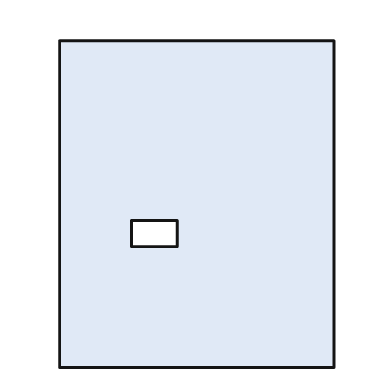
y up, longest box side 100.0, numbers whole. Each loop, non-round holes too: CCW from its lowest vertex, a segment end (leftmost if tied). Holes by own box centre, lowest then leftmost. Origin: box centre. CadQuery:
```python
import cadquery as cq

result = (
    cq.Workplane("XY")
    .moveTo(-42.0, -50.0)
    .lineTo(42.0, -50.0)
    .lineTo(42.0, 50.0)
    .lineTo(-42.0, 50.0)
    .close()
    .moveTo(-20.0, -13.0)
    .lineTo(-6.0, -13.0)
    .lineTo(-6.0, -5.0)
    .lineTo(-20.0, -5.0)
    .close()
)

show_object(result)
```